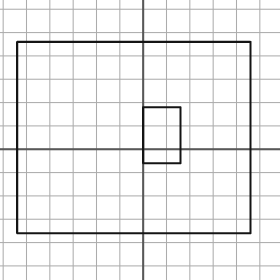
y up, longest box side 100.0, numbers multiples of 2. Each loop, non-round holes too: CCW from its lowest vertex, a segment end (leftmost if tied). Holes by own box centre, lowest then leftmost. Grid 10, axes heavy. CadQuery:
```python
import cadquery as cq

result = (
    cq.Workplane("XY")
    .moveTo(-54.0, -36.0)
    .lineTo(46.0, -36.0)
    .lineTo(46.0, 46.0)
    .lineTo(-54.0, 46.0)
    .close()
    .moveTo(0.0, -6.0)
    .lineTo(16.0, -6.0)
    .lineTo(16.0, 18.0)
    .lineTo(0.0, 18.0)
    .close()
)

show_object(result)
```